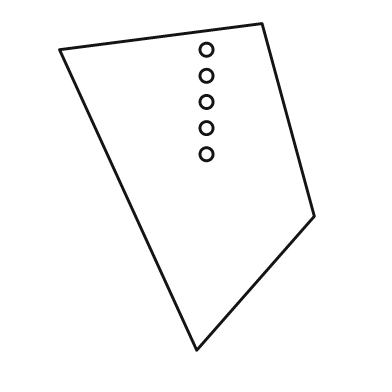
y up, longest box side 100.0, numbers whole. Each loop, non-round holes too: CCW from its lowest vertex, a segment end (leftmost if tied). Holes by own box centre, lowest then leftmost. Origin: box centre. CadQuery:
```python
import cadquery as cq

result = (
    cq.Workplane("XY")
    .moveTo(3.0, -50.0)
    .lineTo(39.0, -9.0)
    .lineTo(23.0, 50.0)
    .lineTo(-39.0, 42.0)
    .close()
    .moveTo(6.0, 10.0)
    .circle(2.0)
    .moveTo(6.0, 18.0)
    .circle(2.0)
    .moveTo(6.0, 26.0)
    .circle(2.0)
    .moveTo(6.0, 34.0)
    .circle(2.0)
    .moveTo(6.0, 42.0)
    .circle(2.0)
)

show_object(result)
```